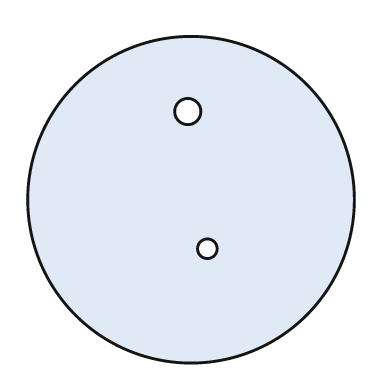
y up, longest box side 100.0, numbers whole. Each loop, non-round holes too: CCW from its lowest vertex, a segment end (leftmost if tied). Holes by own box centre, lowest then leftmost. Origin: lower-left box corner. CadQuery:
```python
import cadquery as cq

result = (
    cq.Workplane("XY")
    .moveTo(50.0, 50.0)
    .circle(50.0)
    .moveTo(55.0, 35.0)
    .circle(3.0)
    .moveTo(49.0, 77.0)
    .circle(4.0)
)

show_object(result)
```